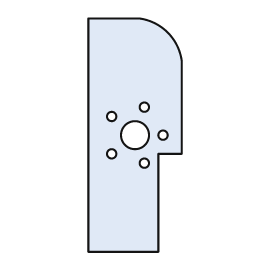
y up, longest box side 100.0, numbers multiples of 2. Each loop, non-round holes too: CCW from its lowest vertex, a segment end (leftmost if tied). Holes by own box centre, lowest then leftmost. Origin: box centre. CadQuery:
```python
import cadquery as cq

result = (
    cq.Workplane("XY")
    .moveTo(-20.0, -50.0)
    .lineTo(10.0, -50.0)
    .lineTo(10.0, -8.0)
    .lineTo(20.0, -8.0)
    .lineTo(20.0, 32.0)
    .threePointArc((14.0, 44.0), (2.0, 50.0))
    .lineTo(-20.0, 50.0)
    .close()
    .moveTo(4.0, -12.0)
    .circle(2.0)
    .moveTo(-10.0, -8.0)
    .circle(2.0)
    .moveTo(0.0, 0.0)
    .circle(6.0)
    .moveTo(12.0, 0.0)
    .circle(2.0)
    .moveTo(-10.0, 8.0)
    .circle(2.0)
    .moveTo(4.0, 12.0)
    .circle(2.0)
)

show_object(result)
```